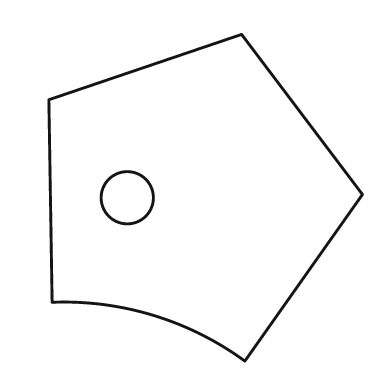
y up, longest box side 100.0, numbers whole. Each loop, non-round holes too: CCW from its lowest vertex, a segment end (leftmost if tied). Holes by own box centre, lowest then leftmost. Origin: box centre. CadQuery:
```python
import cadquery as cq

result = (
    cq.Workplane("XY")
    .moveTo(12.0, -50.0)
    .lineTo(48.0, 1.0)
    .lineTo(11.0, 50.0)
    .lineTo(-48.0, 30.0)
    .lineTo(-47.0, -32.0)
    .threePointArc((-16.0, -36.0), (12.0, -50.0))
    .close()
    .moveTo(-24.0, 0.0)
    .circle(8.0)
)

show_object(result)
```